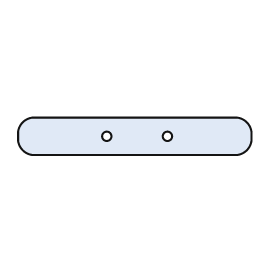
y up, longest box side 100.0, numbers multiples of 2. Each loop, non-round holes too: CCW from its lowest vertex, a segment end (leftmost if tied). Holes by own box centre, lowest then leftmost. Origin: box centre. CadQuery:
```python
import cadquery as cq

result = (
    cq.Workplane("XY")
    .moveTo(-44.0, -8.0)
    .lineTo(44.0, -8.0)
    .threePointArc((48.0, -6.0), (50.0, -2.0))
    .lineTo(50.0, 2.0)
    .threePointArc((48.0, 6.0), (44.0, 8.0))
    .lineTo(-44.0, 8.0)
    .threePointArc((-48.0, 6.0), (-50.0, 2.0))
    .lineTo(-50.0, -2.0)
    .threePointArc((-48.0, -6.0), (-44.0, -8.0))
    .close()
    .moveTo(-12.0, 0.0)
    .circle(2.0)
    .moveTo(14.0, 0.0)
    .circle(2.0)
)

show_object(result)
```